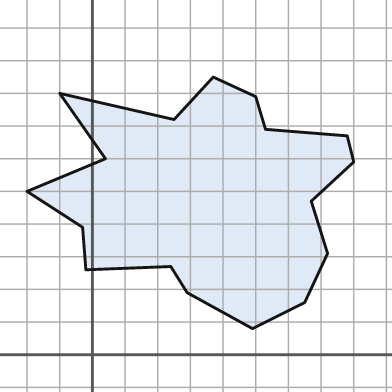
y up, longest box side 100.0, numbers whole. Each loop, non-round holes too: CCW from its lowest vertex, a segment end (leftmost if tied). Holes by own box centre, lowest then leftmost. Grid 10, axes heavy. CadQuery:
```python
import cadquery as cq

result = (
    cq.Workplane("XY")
    .moveTo(49.0, 8.0)
    .lineTo(65.0, 16.0)
    .lineTo(72.0, 31.0)
    .lineTo(67.0, 47.0)
    .lineTo(80.0, 59.0)
    .lineTo(78.0, 67.0)
    .lineTo(53.0, 69.0)
    .lineTo(50.0, 79.0)
    .lineTo(37.0, 85.0)
    .lineTo(25.0, 72.0)
    .lineTo(-10.0, 80.0)
    .lineTo(4.0, 60.0)
    .lineTo(-20.0, 50.0)
    .lineTo(-3.0, 39.0)
    .lineTo(-2.0, 26.0)
    .lineTo(24.0, 27.0)
    .lineTo(29.0, 19.0)
    .close()
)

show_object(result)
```